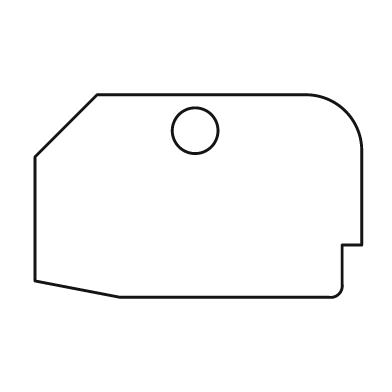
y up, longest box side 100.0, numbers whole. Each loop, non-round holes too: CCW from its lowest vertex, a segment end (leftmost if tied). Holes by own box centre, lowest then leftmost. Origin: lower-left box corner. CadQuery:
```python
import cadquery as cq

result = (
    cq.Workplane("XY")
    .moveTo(26.0, 0.0)
    .lineTo(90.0, 0.0)
    .threePointArc((93.0, 1.0), (94.0, 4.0))
    .lineTo(94.0, 16.0)
    .lineTo(100.0, 16.0)
    .lineTo(100.0, 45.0)
    .threePointArc((95.0, 57.0), (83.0, 62.0))
    .lineTo(19.0, 62.0)
    .lineTo(0.0, 43.0)
    .lineTo(0.0, 5.0)
    .close()
    .moveTo(49.0, 51.0)
    .circle(7.0)
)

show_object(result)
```